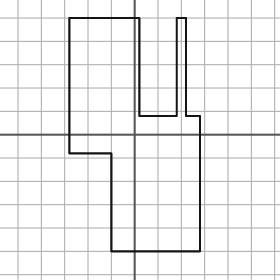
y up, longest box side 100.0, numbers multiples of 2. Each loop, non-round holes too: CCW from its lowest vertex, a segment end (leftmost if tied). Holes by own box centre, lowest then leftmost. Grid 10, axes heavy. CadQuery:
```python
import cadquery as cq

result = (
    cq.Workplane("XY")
    .moveTo(-10.0, -50.0)
    .lineTo(28.0, -50.0)
    .lineTo(28.0, 8.0)
    .lineTo(22.0, 8.0)
    .lineTo(22.0, 50.0)
    .lineTo(18.0, 50.0)
    .lineTo(18.0, 8.0)
    .lineTo(2.0, 8.0)
    .lineTo(2.0, 50.0)
    .lineTo(-28.0, 50.0)
    .lineTo(-28.0, -8.0)
    .lineTo(-10.0, -8.0)
    .close()
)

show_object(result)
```